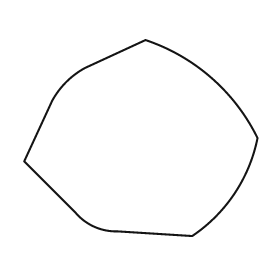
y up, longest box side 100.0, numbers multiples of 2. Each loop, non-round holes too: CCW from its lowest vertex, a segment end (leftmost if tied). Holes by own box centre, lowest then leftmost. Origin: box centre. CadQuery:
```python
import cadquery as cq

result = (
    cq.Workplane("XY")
    .moveTo(22.0, -42.0)
    .threePointArc((40.0, -24.0), (50.0, 0.0))
    .threePointArc((30.0, 26.0), (2.0, 42.0))
    .lineTo(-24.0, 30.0)
    .threePointArc((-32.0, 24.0), (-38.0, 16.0))
    .lineTo(-50.0, -10.0)
    .lineTo(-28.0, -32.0)
    .threePointArc((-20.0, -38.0), (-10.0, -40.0))
    .close()
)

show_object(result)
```